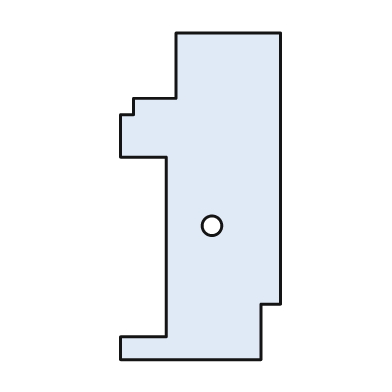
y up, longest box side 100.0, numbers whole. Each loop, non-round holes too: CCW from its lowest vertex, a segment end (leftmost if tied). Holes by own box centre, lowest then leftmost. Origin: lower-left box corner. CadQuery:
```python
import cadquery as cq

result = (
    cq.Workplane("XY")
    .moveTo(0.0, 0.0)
    .lineTo(43.0, 0.0)
    .lineTo(43.0, 17.0)
    .lineTo(49.0, 17.0)
    .lineTo(49.0, 100.0)
    .lineTo(17.0, 100.0)
    .lineTo(17.0, 80.0)
    .lineTo(4.0, 80.0)
    .lineTo(4.0, 75.0)
    .lineTo(0.0, 75.0)
    .lineTo(0.0, 62.0)
    .lineTo(14.0, 62.0)
    .lineTo(14.0, 7.0)
    .lineTo(0.0, 7.0)
    .close()
    .moveTo(28.0, 41.0)
    .circle(3.0)
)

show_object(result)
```